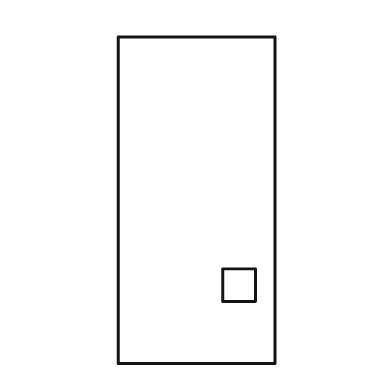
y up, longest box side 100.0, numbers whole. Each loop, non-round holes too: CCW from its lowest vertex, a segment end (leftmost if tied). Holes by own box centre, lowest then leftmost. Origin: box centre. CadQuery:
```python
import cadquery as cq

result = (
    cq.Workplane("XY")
    .moveTo(-24.0, -50.0)
    .lineTo(24.0, -50.0)
    .lineTo(24.0, 50.0)
    .lineTo(-24.0, 50.0)
    .close()
    .moveTo(8.0, -31.0)
    .lineTo(18.0, -31.0)
    .lineTo(18.0, -21.0)
    .lineTo(8.0, -21.0)
    .close()
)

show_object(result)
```